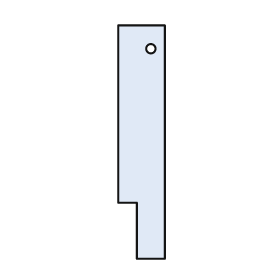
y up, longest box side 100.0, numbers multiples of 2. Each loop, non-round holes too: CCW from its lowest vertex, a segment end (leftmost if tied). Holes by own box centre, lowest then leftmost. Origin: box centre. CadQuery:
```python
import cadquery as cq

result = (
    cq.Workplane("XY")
    .moveTo(-2.0, -50.0)
    .lineTo(10.0, -50.0)
    .lineTo(10.0, 50.0)
    .lineTo(-10.0, 50.0)
    .lineTo(-10.0, -26.0)
    .lineTo(-2.0, -26.0)
    .close()
    .moveTo(4.0, 40.0)
    .circle(2.0)
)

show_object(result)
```